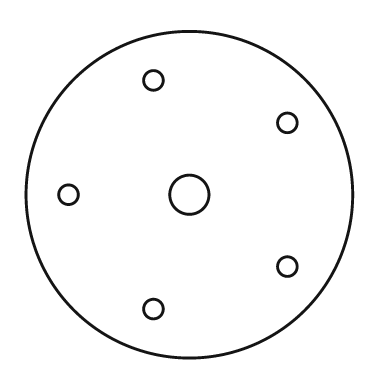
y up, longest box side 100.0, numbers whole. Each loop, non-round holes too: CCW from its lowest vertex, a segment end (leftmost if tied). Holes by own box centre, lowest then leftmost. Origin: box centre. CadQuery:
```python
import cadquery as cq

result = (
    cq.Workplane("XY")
    .moveTo(0.0, 0.0)
    .circle(50.0)
    .moveTo(-11.0, -35.0)
    .circle(3.0)
    .moveTo(30.0, -22.0)
    .circle(3.0)
    .moveTo(-37.0, 0.0)
    .circle(3.0)
    .moveTo(0.0, 0.0)
    .circle(6.0)
    .moveTo(30.0, 22.0)
    .circle(3.0)
    .moveTo(-11.0, 35.0)
    .circle(3.0)
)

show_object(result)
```